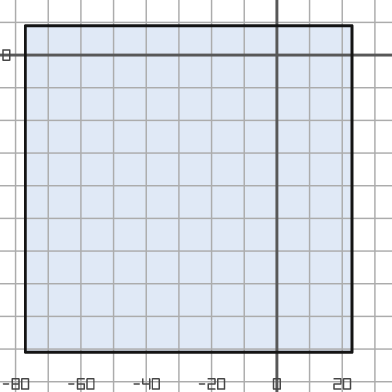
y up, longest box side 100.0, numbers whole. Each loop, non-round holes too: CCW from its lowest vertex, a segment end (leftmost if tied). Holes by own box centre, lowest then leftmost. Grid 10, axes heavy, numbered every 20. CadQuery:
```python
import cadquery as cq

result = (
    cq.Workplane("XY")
    .moveTo(-77.0, -91.0)
    .lineTo(23.0, -91.0)
    .lineTo(23.0, 9.0)
    .lineTo(-77.0, 9.0)
    .close()
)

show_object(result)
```